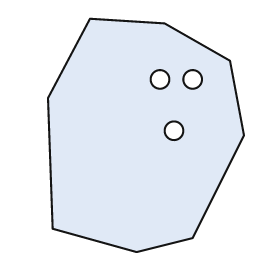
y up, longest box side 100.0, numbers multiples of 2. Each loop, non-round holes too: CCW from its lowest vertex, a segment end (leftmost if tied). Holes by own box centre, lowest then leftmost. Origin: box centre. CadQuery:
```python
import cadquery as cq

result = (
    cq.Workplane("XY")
    .moveTo(-4.0, -50.0)
    .lineTo(20.0, -44.0)
    .lineTo(42.0, 0.0)
    .lineTo(36.0, 32.0)
    .lineTo(8.0, 48.0)
    .lineTo(-24.0, 50.0)
    .lineTo(-42.0, 16.0)
    .lineTo(-40.0, -40.0)
    .close()
    .moveTo(12.0, 2.0)
    .circle(4.0)
    .moveTo(6.0, 24.0)
    .circle(4.0)
    .moveTo(20.0, 24.0)
    .circle(4.0)
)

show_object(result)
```